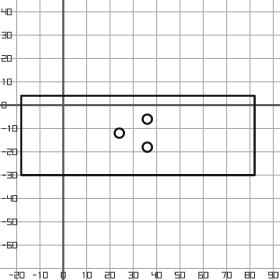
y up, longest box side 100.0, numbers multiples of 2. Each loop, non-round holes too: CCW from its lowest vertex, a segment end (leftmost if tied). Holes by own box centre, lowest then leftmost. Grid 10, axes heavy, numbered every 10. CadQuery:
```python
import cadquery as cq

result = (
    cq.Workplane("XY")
    .moveTo(-18.0, -30.0)
    .lineTo(82.0, -30.0)
    .lineTo(82.0, 4.0)
    .lineTo(-18.0, 4.0)
    .close()
    .moveTo(36.0, -18.0)
    .circle(2.0)
    .moveTo(24.0, -12.0)
    .circle(2.0)
    .moveTo(36.0, -6.0)
    .circle(2.0)
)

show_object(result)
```